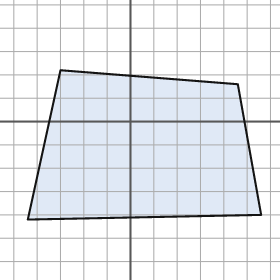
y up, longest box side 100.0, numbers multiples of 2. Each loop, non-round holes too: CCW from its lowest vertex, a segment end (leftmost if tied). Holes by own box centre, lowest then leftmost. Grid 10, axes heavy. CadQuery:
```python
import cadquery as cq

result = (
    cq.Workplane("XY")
    .moveTo(-44.0, -42.0)
    .lineTo(56.0, -40.0)
    .lineTo(46.0, 16.0)
    .lineTo(-30.0, 22.0)
    .close()
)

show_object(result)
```